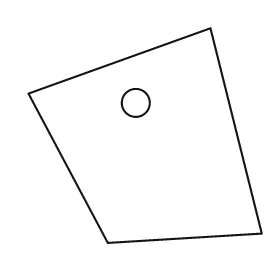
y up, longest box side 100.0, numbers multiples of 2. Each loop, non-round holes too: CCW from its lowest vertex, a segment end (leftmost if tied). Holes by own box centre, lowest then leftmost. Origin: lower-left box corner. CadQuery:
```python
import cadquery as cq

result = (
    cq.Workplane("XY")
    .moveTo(34.0, 0.0)
    .lineTo(100.0, 4.0)
    .lineTo(78.0, 92.0)
    .lineTo(0.0, 64.0)
    .close()
    .moveTo(46.0, 60.0)
    .circle(6.0)
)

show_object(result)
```